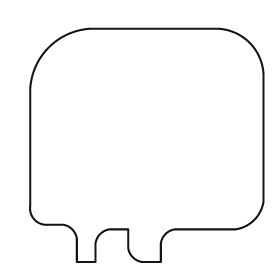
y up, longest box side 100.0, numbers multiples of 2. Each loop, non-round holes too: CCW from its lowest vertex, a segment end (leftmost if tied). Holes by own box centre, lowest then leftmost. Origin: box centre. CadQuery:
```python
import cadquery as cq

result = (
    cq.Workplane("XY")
    .moveTo(-30.0, -50.0)
    .lineTo(-22.0, -50.0)
    .lineTo(-22.0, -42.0)
    .threePointArc((-20.0, -38.0), (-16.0, -36.0))
    .lineTo(-8.0, -36.0)
    .lineTo(-8.0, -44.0)
    .threePointArc((-6.0, -48.0), (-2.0, -50.0))
    .lineTo(6.0, -50.0)
    .lineTo(6.0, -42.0)
    .threePointArc((8.0, -38.0), (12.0, -36.0))
    .lineTo(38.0, -36.0)
    .threePointArc((46.0, -32.0), (50.0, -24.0))
    .lineTo(50.0, 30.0)
    .threePointArc((44.0, 44.0), (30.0, 50.0))
    .lineTo(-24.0, 50.0)
    .threePointArc((-42.0, 42.0), (-50.0, 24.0))
    .lineTo(-50.0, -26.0)
    .threePointArc((-48.0, -32.0), (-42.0, -34.0))
    .lineTo(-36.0, -34.0)
    .threePointArc((-32.0, -36.0), (-30.0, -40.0))
    .close()
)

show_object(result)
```